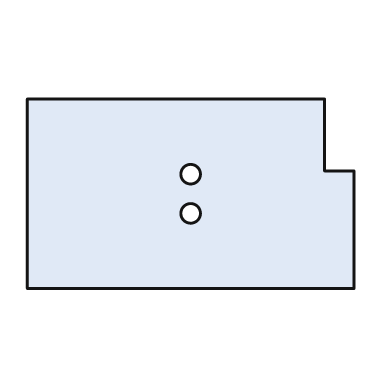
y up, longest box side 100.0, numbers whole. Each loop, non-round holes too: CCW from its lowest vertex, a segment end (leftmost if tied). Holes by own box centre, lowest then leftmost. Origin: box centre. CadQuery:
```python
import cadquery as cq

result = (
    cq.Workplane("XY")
    .moveTo(-50.0, -29.0)
    .lineTo(50.0, -29.0)
    .lineTo(50.0, 7.0)
    .lineTo(41.0, 7.0)
    .lineTo(41.0, 29.0)
    .lineTo(-50.0, 29.0)
    .close()
    .moveTo(0.0, -6.0)
    .circle(3.0)
    .moveTo(0.0, 6.0)
    .circle(3.0)
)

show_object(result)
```